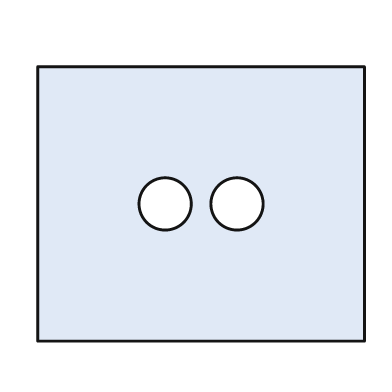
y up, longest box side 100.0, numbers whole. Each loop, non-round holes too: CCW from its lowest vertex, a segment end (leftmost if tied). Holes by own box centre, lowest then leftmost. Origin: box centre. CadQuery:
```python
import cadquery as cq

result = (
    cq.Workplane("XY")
    .moveTo(-50.0, -42.0)
    .lineTo(50.0, -42.0)
    .lineTo(50.0, 42.0)
    .lineTo(-50.0, 42.0)
    .close()
    .moveTo(-11.0, 0.0)
    .circle(8.0)
    .moveTo(11.0, 0.0)
    .circle(8.0)
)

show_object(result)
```